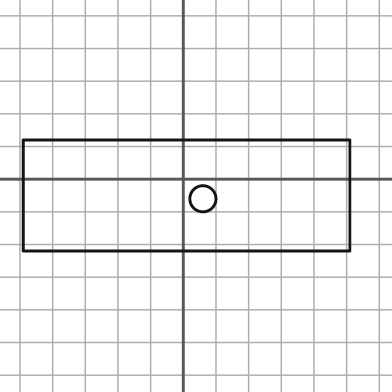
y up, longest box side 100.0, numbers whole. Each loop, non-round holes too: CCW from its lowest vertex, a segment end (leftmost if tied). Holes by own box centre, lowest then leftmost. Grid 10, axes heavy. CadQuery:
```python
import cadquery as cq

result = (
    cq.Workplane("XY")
    .moveTo(-49.0, -22.0)
    .lineTo(51.0, -22.0)
    .lineTo(51.0, 12.0)
    .lineTo(-49.0, 12.0)
    .close()
    .moveTo(6.0, -6.0)
    .circle(4.0)
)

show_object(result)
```